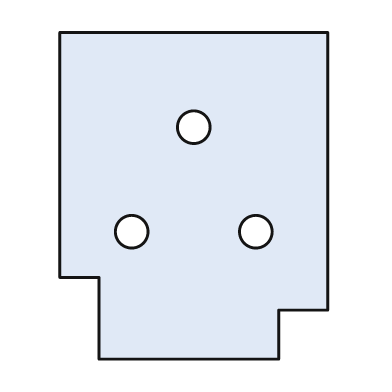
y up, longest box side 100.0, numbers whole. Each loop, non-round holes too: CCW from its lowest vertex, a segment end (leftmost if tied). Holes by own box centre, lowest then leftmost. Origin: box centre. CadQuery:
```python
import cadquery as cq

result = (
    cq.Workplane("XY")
    .moveTo(-29.0, -50.0)
    .lineTo(26.0, -50.0)
    .lineTo(26.0, -35.0)
    .lineTo(41.0, -35.0)
    .lineTo(41.0, 50.0)
    .lineTo(-41.0, 50.0)
    .lineTo(-41.0, -25.0)
    .lineTo(-29.0, -25.0)
    .close()
    .moveTo(-19.0, -11.0)
    .circle(5.0)
    .moveTo(19.0, -11.0)
    .circle(5.0)
    .moveTo(0.0, 21.0)
    .circle(5.0)
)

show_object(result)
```